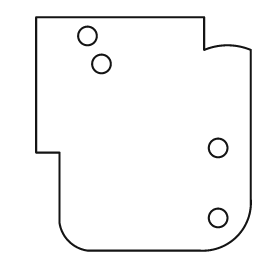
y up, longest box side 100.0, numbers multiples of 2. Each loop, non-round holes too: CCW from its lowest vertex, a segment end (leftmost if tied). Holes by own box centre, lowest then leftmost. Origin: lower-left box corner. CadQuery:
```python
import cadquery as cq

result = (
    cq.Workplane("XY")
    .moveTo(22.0, 0.0)
    .lineTo(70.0, 0.0)
    .threePointArc((86.0, 6.0), (92.0, 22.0))
    .lineTo(92.0, 86.0)
    .threePointArc((82.0, 88.0), (72.0, 86.0))
    .lineTo(72.0, 100.0)
    .lineTo(0.0, 100.0)
    .lineTo(0.0, 42.0)
    .lineTo(10.0, 42.0)
    .lineTo(10.0, 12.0)
    .threePointArc((14.0, 4.0), (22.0, 0.0))
    .close()
    .moveTo(78.0, 14.0)
    .circle(4.0)
    .moveTo(78.0, 44.0)
    .circle(4.0)
    .moveTo(28.0, 80.0)
    .circle(4.0)
    .moveTo(22.0, 92.0)
    .circle(4.0)
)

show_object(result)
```